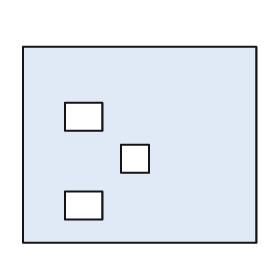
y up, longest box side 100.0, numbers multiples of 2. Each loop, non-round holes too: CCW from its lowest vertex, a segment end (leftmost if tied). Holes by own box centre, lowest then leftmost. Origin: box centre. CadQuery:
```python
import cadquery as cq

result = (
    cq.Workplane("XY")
    .moveTo(-50.0, -42.0)
    .lineTo(50.0, -42.0)
    .lineTo(50.0, 42.0)
    .lineTo(-50.0, 42.0)
    .close()
    .moveTo(-32.0, -32.0)
    .lineTo(-16.0, -32.0)
    .lineTo(-16.0, -20.0)
    .lineTo(-32.0, -20.0)
    .close()
    .moveTo(-8.0, -12.0)
    .lineTo(4.0, -12.0)
    .lineTo(4.0, 0.0)
    .lineTo(-8.0, 0.0)
    .close()
    .moveTo(-32.0, 6.0)
    .lineTo(-16.0, 6.0)
    .lineTo(-16.0, 18.0)
    .lineTo(-32.0, 18.0)
    .close()
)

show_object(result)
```